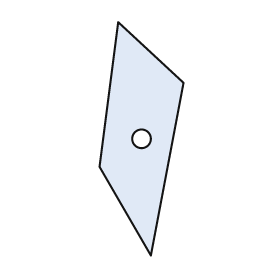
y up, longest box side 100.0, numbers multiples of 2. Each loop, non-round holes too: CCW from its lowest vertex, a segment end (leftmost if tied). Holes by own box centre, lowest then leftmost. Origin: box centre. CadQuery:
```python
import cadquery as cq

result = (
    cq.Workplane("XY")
    .moveTo(4.0, -50.0)
    .lineTo(18.0, 24.0)
    .lineTo(-10.0, 50.0)
    .lineTo(-18.0, -12.0)
    .close()
    .moveTo(0.0, 0.0)
    .circle(4.0)
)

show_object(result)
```